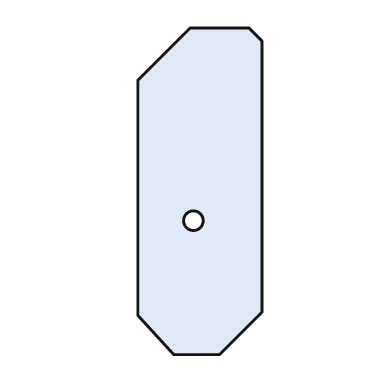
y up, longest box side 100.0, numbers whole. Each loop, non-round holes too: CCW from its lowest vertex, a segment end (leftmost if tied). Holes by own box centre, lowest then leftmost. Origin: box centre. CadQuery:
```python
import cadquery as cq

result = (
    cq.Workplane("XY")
    .moveTo(-8.0, -50.0)
    .lineTo(6.0, -50.0)
    .lineTo(19.0, -37.0)
    .lineTo(19.0, 46.0)
    .lineTo(15.0, 50.0)
    .lineTo(-3.0, 50.0)
    .lineTo(-19.0, 34.0)
    .lineTo(-19.0, -38.0)
    .close()
    .moveTo(-2.0, -9.0)
    .circle(3.0)
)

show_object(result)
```